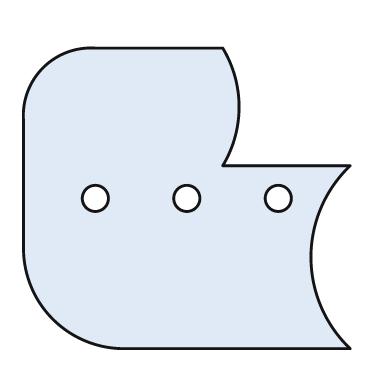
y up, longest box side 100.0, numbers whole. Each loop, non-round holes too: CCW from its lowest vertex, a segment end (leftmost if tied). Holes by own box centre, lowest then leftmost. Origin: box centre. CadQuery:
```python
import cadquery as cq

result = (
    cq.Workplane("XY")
    .moveTo(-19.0, -46.0)
    .lineTo(50.0, -46.0)
    .threePointArc((38.0, -18.0), (50.0, 10.0))
    .lineTo(11.0, 10.0)
    .threePointArc((16.0, 28.0), (11.0, 46.0))
    .lineTo(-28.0, 46.0)
    .threePointArc((-44.0, 40.0), (-50.0, 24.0))
    .lineTo(-50.0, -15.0)
    .threePointArc((-41.0, -37.0), (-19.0, -46.0))
    .close()
    .moveTo(-28.0, 0.0)
    .circle(4.0)
    .moveTo(0.0, 0.0)
    .circle(4.0)
    .moveTo(28.0, 0.0)
    .circle(4.0)
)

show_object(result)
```